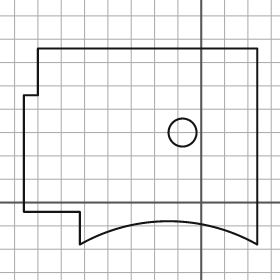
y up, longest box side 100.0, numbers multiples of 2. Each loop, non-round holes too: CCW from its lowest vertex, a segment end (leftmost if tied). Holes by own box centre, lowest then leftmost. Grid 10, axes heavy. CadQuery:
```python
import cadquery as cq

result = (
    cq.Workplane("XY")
    .moveTo(-52.0, -18.0)
    .threePointArc((-14.0, -8.0), (24.0, -18.0))
    .lineTo(24.0, 66.0)
    .lineTo(-70.0, 66.0)
    .lineTo(-70.0, 46.0)
    .lineTo(-76.0, 46.0)
    .lineTo(-76.0, -4.0)
    .lineTo(-52.0, -4.0)
    .close()
    .moveTo(-8.0, 30.0)
    .circle(6.0)
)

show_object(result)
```